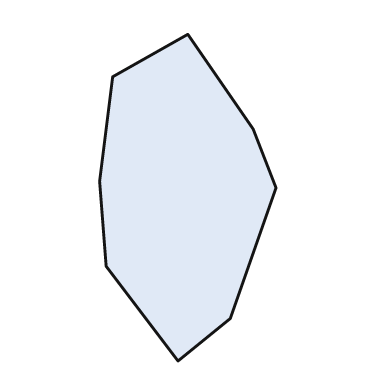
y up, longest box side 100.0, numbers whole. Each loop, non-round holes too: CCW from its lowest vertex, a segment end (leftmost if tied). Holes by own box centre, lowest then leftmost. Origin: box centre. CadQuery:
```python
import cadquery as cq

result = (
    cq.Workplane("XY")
    .moveTo(-3.0, -50.0)
    .lineTo(13.0, -37.0)
    .lineTo(27.0, 3.0)
    .lineTo(20.0, 21.0)
    .lineTo(0.0, 50.0)
    .lineTo(-23.0, 37.0)
    .lineTo(-27.0, 5.0)
    .lineTo(-25.0, -21.0)
    .close()
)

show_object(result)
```